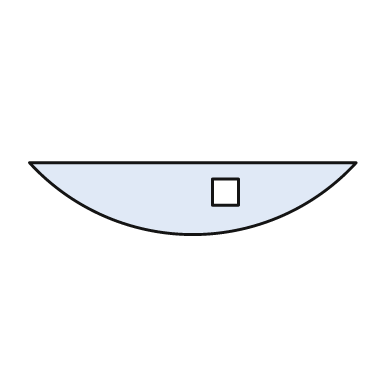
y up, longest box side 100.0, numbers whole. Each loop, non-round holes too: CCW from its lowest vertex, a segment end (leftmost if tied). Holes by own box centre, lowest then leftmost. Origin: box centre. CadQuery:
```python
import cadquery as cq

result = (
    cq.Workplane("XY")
    .moveTo(-50.0, 11.0)
    .threePointArc((0.0, -11.0), (50.0, 11.0))
    .close()
    .moveTo(6.0, -2.0)
    .lineTo(14.0, -2.0)
    .lineTo(14.0, 6.0)
    .lineTo(6.0, 6.0)
    .close()
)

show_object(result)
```